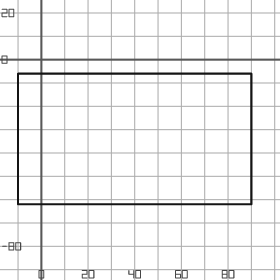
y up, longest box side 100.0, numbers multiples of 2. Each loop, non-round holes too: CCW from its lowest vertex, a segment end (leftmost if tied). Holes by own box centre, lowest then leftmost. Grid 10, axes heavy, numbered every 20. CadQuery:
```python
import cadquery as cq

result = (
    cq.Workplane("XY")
    .moveTo(-10.0, -62.0)
    .lineTo(90.0, -62.0)
    .lineTo(90.0, -6.0)
    .lineTo(-10.0, -6.0)
    .close()
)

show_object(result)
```